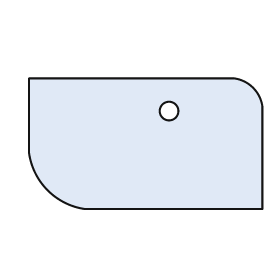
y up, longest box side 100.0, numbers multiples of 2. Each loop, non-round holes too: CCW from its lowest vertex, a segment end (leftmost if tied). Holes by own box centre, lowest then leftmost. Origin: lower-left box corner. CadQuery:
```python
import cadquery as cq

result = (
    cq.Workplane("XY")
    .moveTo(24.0, 0.0)
    .lineTo(100.0, 0.0)
    .lineTo(100.0, 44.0)
    .threePointArc((96.0, 52.0), (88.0, 56.0))
    .lineTo(0.0, 56.0)
    .lineTo(0.0, 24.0)
    .threePointArc((8.0, 8.0), (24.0, 0.0))
    .close()
    .moveTo(60.0, 42.0)
    .circle(4.0)
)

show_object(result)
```